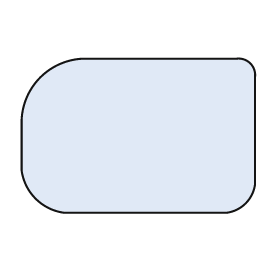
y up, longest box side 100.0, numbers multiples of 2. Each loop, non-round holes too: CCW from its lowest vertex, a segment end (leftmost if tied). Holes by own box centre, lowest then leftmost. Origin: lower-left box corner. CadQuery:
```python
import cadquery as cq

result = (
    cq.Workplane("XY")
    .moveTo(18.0, 0.0)
    .lineTo(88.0, 0.0)
    .threePointArc((96.0, 4.0), (100.0, 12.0))
    .lineTo(100.0, 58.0)
    .threePointArc((98.0, 64.0), (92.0, 66.0))
    .lineTo(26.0, 66.0)
    .threePointArc((8.0, 58.0), (0.0, 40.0))
    .lineTo(0.0, 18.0)
    .threePointArc((6.0, 6.0), (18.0, 0.0))
    .close()
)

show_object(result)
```